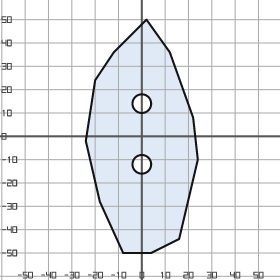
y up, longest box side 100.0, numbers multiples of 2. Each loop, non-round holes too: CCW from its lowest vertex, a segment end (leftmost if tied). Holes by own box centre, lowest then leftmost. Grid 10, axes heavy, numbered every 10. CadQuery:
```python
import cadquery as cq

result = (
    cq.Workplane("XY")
    .moveTo(-8.0, -50.0)
    .lineTo(4.0, -50.0)
    .lineTo(16.0, -44.0)
    .lineTo(24.0, -10.0)
    .lineTo(22.0, 8.0)
    .lineTo(12.0, 36.0)
    .lineTo(2.0, 50.0)
    .lineTo(-12.0, 36.0)
    .lineTo(-20.0, 24.0)
    .lineTo(-24.0, -2.0)
    .lineTo(-18.0, -28.0)
    .close()
    .moveTo(0.0, -12.0)
    .circle(4.0)
    .moveTo(0.0, 14.0)
    .circle(4.0)
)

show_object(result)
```